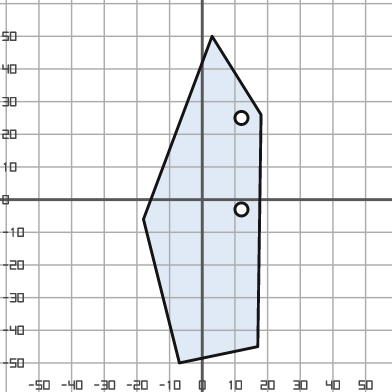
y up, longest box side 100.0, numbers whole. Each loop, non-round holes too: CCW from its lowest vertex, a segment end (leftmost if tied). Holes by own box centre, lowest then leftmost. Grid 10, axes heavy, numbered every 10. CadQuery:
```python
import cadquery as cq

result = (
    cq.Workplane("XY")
    .moveTo(-7.0, -50.0)
    .lineTo(17.0, -45.0)
    .lineTo(18.0, 26.0)
    .lineTo(3.0, 50.0)
    .lineTo(-18.0, -6.0)
    .close()
    .moveTo(12.0, -3.0)
    .circle(2.0)
    .moveTo(12.0, 25.0)
    .circle(2.0)
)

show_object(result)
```